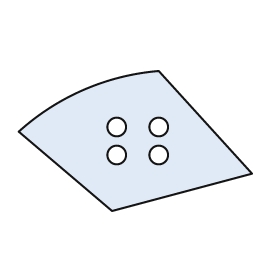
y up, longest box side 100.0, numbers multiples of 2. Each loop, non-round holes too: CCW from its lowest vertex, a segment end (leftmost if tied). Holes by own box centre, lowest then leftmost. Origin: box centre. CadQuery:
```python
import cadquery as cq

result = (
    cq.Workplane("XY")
    .moveTo(-10.0, -30.0)
    .lineTo(50.0, -14.0)
    .lineTo(10.0, 30.0)
    .threePointArc((-22.0, 22.0), (-50.0, 4.0))
    .close()
    .moveTo(-8.0, -6.0)
    .circle(4.0)
    .moveTo(10.0, -6.0)
    .circle(4.0)
    .moveTo(-8.0, 6.0)
    .circle(4.0)
    .moveTo(10.0, 6.0)
    .circle(4.0)
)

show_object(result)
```